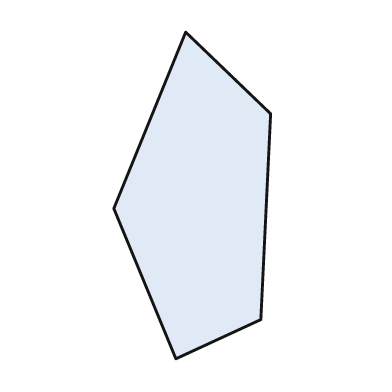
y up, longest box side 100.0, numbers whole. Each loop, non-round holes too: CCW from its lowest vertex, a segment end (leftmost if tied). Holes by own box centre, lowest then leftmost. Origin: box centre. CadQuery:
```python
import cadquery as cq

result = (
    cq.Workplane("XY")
    .moveTo(-5.0, -50.0)
    .lineTo(21.0, -38.0)
    .lineTo(24.0, 25.0)
    .lineTo(-2.0, 50.0)
    .lineTo(-24.0, -4.0)
    .close()
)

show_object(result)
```